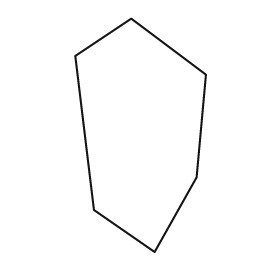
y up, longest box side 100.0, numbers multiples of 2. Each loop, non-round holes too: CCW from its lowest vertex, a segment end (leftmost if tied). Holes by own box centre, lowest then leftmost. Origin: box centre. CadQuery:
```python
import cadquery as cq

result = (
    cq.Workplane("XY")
    .moveTo(6.0, -50.0)
    .lineTo(24.0, -18.0)
    .lineTo(28.0, 26.0)
    .lineTo(-4.0, 50.0)
    .lineTo(-28.0, 34.0)
    .lineTo(-20.0, -32.0)
    .close()
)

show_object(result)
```